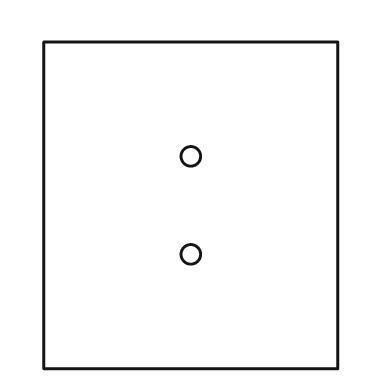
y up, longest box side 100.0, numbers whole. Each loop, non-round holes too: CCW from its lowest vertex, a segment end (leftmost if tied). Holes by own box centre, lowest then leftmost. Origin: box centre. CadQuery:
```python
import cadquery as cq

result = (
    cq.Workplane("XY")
    .moveTo(-45.0, -50.0)
    .lineTo(45.0, -50.0)
    .lineTo(45.0, 50.0)
    .lineTo(-45.0, 50.0)
    .close()
    .moveTo(0.0, -15.0)
    .circle(3.0)
    .moveTo(0.0, 15.0)
    .circle(3.0)
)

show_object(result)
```